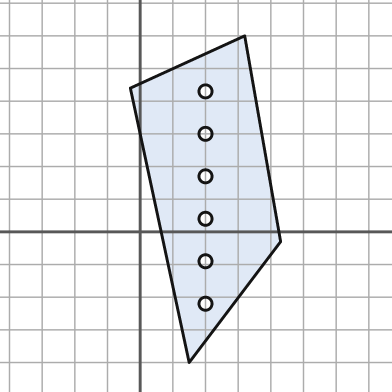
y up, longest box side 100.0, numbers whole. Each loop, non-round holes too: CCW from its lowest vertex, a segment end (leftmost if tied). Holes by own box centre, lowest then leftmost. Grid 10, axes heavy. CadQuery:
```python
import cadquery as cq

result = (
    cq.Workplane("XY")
    .moveTo(15.0, -40.0)
    .lineTo(43.0, -3.0)
    .lineTo(32.0, 60.0)
    .lineTo(-3.0, 44.0)
    .close()
    .moveTo(20.0, -22.0)
    .circle(2.0)
    .moveTo(20.0, -9.0)
    .circle(2.0)
    .moveTo(20.0, 4.0)
    .circle(2.0)
    .moveTo(20.0, 17.0)
    .circle(2.0)
    .moveTo(20.0, 30.0)
    .circle(2.0)
    .moveTo(20.0, 43.0)
    .circle(2.0)
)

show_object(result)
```